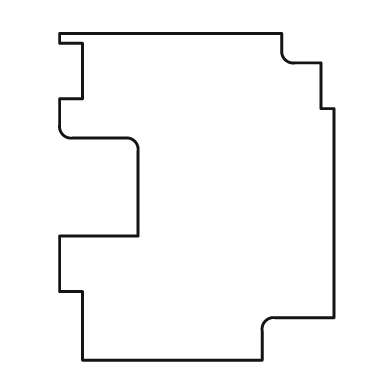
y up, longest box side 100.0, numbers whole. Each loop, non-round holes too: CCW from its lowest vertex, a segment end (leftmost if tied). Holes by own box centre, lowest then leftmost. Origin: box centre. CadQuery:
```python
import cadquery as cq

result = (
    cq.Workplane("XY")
    .moveTo(-35.0, -50.0)
    .lineTo(20.0, -50.0)
    .lineTo(20.0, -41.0)
    .threePointArc((21.0, -38.0), (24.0, -37.0))
    .lineTo(42.0, -37.0)
    .lineTo(42.0, 27.0)
    .lineTo(38.0, 27.0)
    .lineTo(38.0, 41.0)
    .lineTo(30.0, 41.0)
    .threePointArc((27.0, 42.0), (26.0, 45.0))
    .lineTo(26.0, 50.0)
    .lineTo(-42.0, 50.0)
    .lineTo(-42.0, 47.0)
    .lineTo(-35.0, 47.0)
    .lineTo(-35.0, 30.0)
    .lineTo(-42.0, 30.0)
    .lineTo(-42.0, 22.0)
    .threePointArc((-41.0, 19.0), (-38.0, 18.0))
    .lineTo(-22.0, 18.0)
    .threePointArc((-19.0, 17.0), (-18.0, 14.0))
    .lineTo(-18.0, -12.0)
    .lineTo(-42.0, -12.0)
    .lineTo(-42.0, -29.0)
    .lineTo(-35.0, -29.0)
    .close()
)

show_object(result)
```